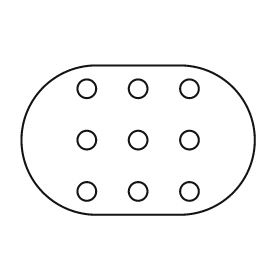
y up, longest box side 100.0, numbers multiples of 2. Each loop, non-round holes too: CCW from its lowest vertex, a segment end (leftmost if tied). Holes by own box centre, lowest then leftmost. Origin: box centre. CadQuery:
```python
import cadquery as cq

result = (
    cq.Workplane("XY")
    .moveTo(-18.0, -32.0)
    .lineTo(18.0, -32.0)
    .threePointArc((50.0, 0.0), (18.0, 32.0))
    .lineTo(-18.0, 32.0)
    .threePointArc((-50.0, 0.0), (-18.0, -32.0))
    .close()
    .moveTo(-22.0, -22.0)
    .circle(4.0)
    .moveTo(0.0, -22.0)
    .circle(4.0)
    .moveTo(22.0, -22.0)
    .circle(4.0)
    .moveTo(-22.0, 0.0)
    .circle(4.0)
    .moveTo(0.0, 0.0)
    .circle(4.0)
    .moveTo(22.0, 0.0)
    .circle(4.0)
    .moveTo(-22.0, 22.0)
    .circle(4.0)
    .moveTo(0.0, 22.0)
    .circle(4.0)
    .moveTo(22.0, 22.0)
    .circle(4.0)
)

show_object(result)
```